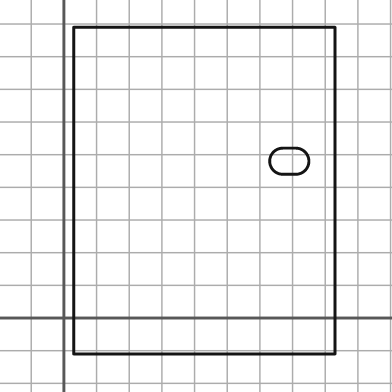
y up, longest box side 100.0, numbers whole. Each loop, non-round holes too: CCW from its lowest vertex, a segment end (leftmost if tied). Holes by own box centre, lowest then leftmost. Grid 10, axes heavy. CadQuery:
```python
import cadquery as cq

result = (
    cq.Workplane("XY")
    .moveTo(3.0, -11.0)
    .lineTo(83.0, -11.0)
    .lineTo(83.0, 89.0)
    .lineTo(3.0, 89.0)
    .close()
    .moveTo(67.0, 44.0)
    .lineTo(71.0, 44.0)
    .threePointArc((75.0, 48.0), (71.0, 52.0))
    .lineTo(67.0, 52.0)
    .threePointArc((63.0, 48.0), (67.0, 44.0))
    .close()
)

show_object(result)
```